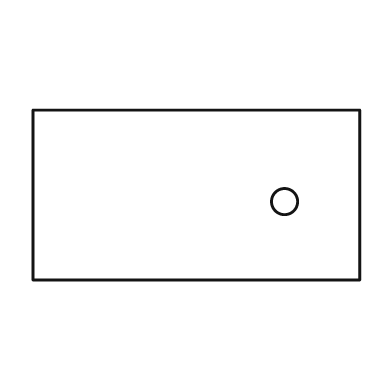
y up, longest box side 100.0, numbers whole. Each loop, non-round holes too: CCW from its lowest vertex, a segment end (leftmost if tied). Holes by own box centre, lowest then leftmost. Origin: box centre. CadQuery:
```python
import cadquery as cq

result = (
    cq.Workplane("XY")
    .moveTo(-50.0, -26.0)
    .lineTo(50.0, -26.0)
    .lineTo(50.0, 26.0)
    .lineTo(-50.0, 26.0)
    .close()
    .moveTo(27.0, -2.0)
    .circle(4.0)
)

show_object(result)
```